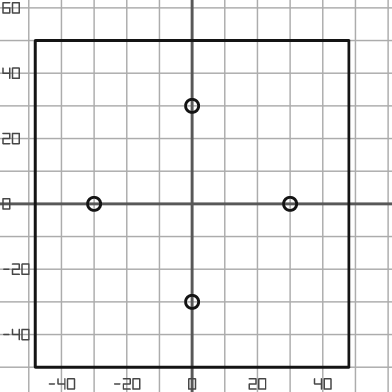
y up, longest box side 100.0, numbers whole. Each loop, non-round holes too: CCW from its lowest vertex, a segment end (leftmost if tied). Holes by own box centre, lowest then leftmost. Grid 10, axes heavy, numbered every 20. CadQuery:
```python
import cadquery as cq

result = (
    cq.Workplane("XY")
    .moveTo(-48.0, -50.0)
    .lineTo(48.0, -50.0)
    .lineTo(48.0, 50.0)
    .lineTo(-48.0, 50.0)
    .close()
    .moveTo(0.0, -30.0)
    .circle(2.0)
    .moveTo(-30.0, 0.0)
    .circle(2.0)
    .moveTo(30.0, 0.0)
    .circle(2.0)
    .moveTo(0.0, 30.0)
    .circle(2.0)
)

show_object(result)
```